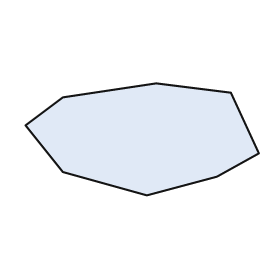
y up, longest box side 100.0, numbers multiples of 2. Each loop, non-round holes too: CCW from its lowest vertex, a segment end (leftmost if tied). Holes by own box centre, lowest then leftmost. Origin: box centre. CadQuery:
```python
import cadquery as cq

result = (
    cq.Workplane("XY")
    .moveTo(2.0, -24.0)
    .lineTo(32.0, -16.0)
    .lineTo(50.0, -6.0)
    .lineTo(38.0, 20.0)
    .lineTo(6.0, 24.0)
    .lineTo(-34.0, 18.0)
    .lineTo(-50.0, 6.0)
    .lineTo(-34.0, -14.0)
    .close()
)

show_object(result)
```